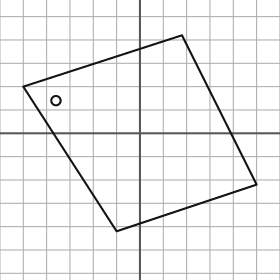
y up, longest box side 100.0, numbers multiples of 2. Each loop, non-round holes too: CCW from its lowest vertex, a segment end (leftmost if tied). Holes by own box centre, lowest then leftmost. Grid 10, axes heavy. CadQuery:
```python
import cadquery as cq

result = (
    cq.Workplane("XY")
    .moveTo(-10.0, -42.0)
    .lineTo(50.0, -22.0)
    .lineTo(18.0, 42.0)
    .lineTo(-50.0, 20.0)
    .close()
    .moveTo(-36.0, 14.0)
    .circle(2.0)
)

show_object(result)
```